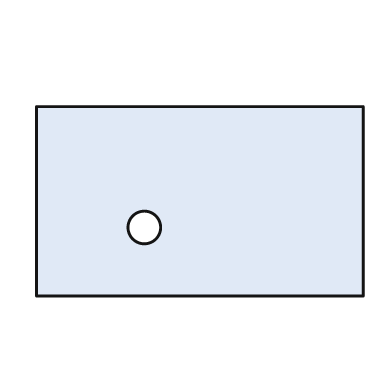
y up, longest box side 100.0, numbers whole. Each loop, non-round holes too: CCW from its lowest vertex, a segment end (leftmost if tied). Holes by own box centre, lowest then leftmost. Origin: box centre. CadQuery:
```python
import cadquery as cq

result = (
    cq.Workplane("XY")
    .moveTo(-50.0, -29.0)
    .lineTo(50.0, -29.0)
    .lineTo(50.0, 29.0)
    .lineTo(-50.0, 29.0)
    .close()
    .moveTo(-17.0, -8.0)
    .circle(5.0)
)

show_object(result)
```